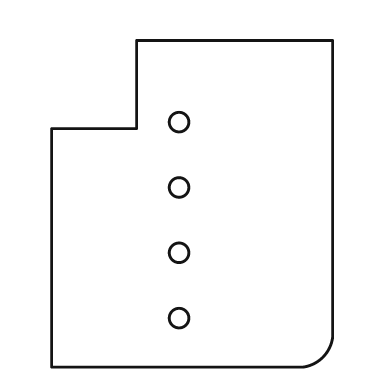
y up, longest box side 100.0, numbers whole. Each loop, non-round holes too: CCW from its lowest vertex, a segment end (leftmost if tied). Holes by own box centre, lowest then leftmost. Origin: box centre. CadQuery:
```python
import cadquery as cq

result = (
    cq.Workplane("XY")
    .moveTo(-43.0, -50.0)
    .lineTo(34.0, -50.0)
    .threePointArc((40.0, -47.0), (43.0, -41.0))
    .lineTo(43.0, 50.0)
    .lineTo(-17.0, 50.0)
    .lineTo(-17.0, 23.0)
    .lineTo(-43.0, 23.0)
    .close()
    .moveTo(-4.0, -35.0)
    .circle(3.0)
    .moveTo(-4.0, -15.0)
    .circle(3.0)
    .moveTo(-4.0, 5.0)
    .circle(3.0)
    .moveTo(-4.0, 25.0)
    .circle(3.0)
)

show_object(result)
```